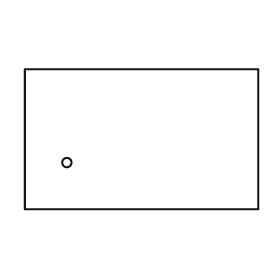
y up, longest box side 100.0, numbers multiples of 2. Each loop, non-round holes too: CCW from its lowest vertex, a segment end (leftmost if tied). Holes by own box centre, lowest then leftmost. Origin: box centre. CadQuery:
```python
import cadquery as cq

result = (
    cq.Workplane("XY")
    .moveTo(-50.0, -30.0)
    .lineTo(50.0, -30.0)
    .lineTo(50.0, 30.0)
    .lineTo(-50.0, 30.0)
    .close()
    .moveTo(-32.0, -10.0)
    .circle(2.0)
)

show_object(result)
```